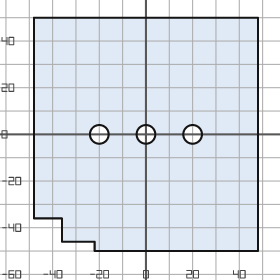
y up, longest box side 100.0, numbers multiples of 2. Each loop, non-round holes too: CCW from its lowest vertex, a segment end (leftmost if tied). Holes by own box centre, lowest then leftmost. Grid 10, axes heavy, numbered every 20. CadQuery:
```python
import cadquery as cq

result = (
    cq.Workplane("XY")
    .moveTo(-22.0, -50.0)
    .lineTo(48.0, -50.0)
    .lineTo(48.0, 50.0)
    .lineTo(-48.0, 50.0)
    .lineTo(-48.0, -36.0)
    .lineTo(-36.0, -36.0)
    .lineTo(-36.0, -46.0)
    .lineTo(-22.0, -46.0)
    .close()
    .moveTo(-20.0, 0.0)
    .circle(4.0)
    .moveTo(0.0, 0.0)
    .circle(4.0)
    .moveTo(20.0, 0.0)
    .circle(4.0)
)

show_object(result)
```